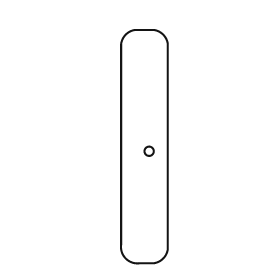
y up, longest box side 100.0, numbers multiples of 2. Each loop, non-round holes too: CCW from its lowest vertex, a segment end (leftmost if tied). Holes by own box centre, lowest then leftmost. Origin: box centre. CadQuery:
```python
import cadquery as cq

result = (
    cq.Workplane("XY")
    .moveTo(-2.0, -50.0)
    .lineTo(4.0, -50.0)
    .threePointArc((8.0, -48.0), (10.0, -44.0))
    .lineTo(10.0, 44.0)
    .threePointArc((8.0, 48.0), (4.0, 50.0))
    .lineTo(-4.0, 50.0)
    .threePointArc((-8.0, 48.0), (-10.0, 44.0))
    .lineTo(-10.0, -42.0)
    .threePointArc((-8.0, -48.0), (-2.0, -50.0))
    .close()
    .moveTo(2.0, -2.0)
    .circle(2.0)
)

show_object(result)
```